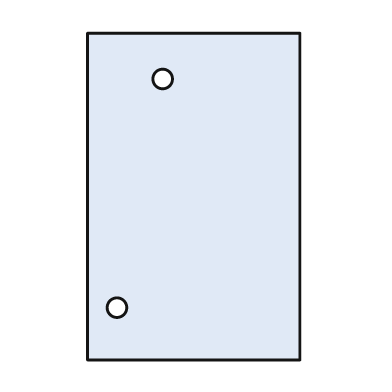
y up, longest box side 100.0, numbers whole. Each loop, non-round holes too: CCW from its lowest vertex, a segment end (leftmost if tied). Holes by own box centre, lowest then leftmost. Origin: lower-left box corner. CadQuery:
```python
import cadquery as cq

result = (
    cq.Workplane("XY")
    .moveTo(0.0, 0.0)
    .lineTo(65.0, 0.0)
    .lineTo(65.0, 100.0)
    .lineTo(0.0, 100.0)
    .close()
    .moveTo(9.0, 16.0)
    .circle(3.0)
    .moveTo(23.0, 86.0)
    .circle(3.0)
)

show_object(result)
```